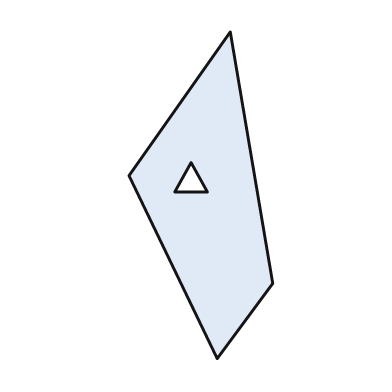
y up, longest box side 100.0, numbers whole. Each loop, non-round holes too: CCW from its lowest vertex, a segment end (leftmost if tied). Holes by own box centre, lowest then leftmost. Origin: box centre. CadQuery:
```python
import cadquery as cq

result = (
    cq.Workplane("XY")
    .moveTo(5.0, -50.0)
    .lineTo(22.0, -27.0)
    .lineTo(9.0, 50.0)
    .lineTo(-22.0, 6.0)
    .close()
    .moveTo(-8.0, 1.0)
    .lineTo(2.0, 1.0)
    .lineTo(-3.0, 10.0)
    .close()
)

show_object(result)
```